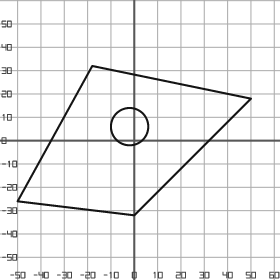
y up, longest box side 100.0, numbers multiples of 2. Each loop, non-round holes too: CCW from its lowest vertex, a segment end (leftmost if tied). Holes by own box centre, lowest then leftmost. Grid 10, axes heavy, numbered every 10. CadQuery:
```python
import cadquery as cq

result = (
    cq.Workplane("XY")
    .moveTo(0.0, -32.0)
    .lineTo(50.0, 18.0)
    .lineTo(-18.0, 32.0)
    .lineTo(-50.0, -26.0)
    .close()
    .moveTo(-2.0, 6.0)
    .circle(8.0)
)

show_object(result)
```